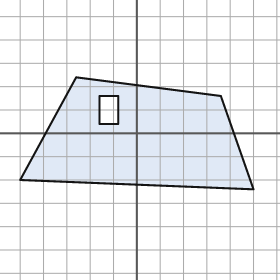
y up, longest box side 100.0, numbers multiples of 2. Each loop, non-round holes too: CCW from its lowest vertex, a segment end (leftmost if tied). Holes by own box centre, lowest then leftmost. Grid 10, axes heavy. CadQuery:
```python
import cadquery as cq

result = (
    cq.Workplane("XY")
    .moveTo(50.0, -24.0)
    .lineTo(36.0, 16.0)
    .lineTo(-26.0, 24.0)
    .lineTo(-50.0, -20.0)
    .close()
    .moveTo(-16.0, 4.0)
    .lineTo(-8.0, 4.0)
    .lineTo(-8.0, 16.0)
    .lineTo(-16.0, 16.0)
    .close()
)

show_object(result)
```